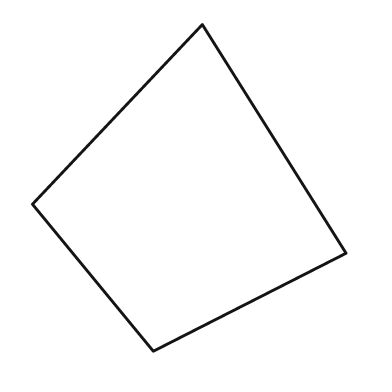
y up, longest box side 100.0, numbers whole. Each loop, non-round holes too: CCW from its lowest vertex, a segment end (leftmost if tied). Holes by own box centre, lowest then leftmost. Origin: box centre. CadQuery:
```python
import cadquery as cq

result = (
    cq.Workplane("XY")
    .moveTo(-11.0, -50.0)
    .lineTo(48.0, -20.0)
    .lineTo(4.0, 50.0)
    .lineTo(-48.0, -5.0)
    .close()
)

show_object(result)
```